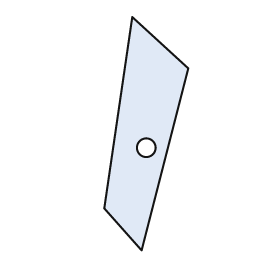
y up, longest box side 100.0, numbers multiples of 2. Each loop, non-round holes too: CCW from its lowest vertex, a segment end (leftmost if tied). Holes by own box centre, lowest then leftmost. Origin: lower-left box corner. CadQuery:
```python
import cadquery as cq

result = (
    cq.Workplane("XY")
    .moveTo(16.0, 0.0)
    .lineTo(36.0, 78.0)
    .lineTo(12.0, 100.0)
    .lineTo(0.0, 18.0)
    .close()
    .moveTo(18.0, 44.0)
    .circle(4.0)
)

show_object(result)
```